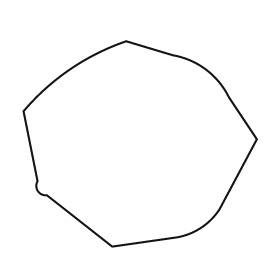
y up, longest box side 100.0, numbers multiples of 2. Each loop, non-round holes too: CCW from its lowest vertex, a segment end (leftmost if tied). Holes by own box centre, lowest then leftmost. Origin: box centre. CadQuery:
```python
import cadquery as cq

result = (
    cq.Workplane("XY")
    .moveTo(-12.0, -44.0)
    .lineTo(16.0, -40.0)
    .threePointArc((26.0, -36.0), (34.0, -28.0))
    .lineTo(50.0, 2.0)
    .lineTo(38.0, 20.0)
    .threePointArc((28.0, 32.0), (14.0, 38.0))
    .lineTo(-6.0, 44.0)
    .threePointArc((-30.0, 32.0), (-50.0, 14.0))
    .lineTo(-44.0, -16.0)
    .threePointArc((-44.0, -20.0), (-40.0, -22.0))
    .close()
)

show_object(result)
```